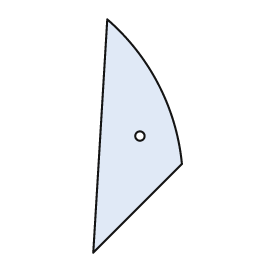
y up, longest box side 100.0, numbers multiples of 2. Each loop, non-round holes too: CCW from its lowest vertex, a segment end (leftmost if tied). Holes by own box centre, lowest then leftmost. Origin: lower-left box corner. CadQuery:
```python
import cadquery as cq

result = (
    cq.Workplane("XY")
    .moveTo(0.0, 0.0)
    .lineTo(38.0, 38.0)
    .threePointArc((28.0, 72.0), (6.0, 100.0))
    .close()
    .moveTo(20.0, 50.0)
    .circle(2.0)
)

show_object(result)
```